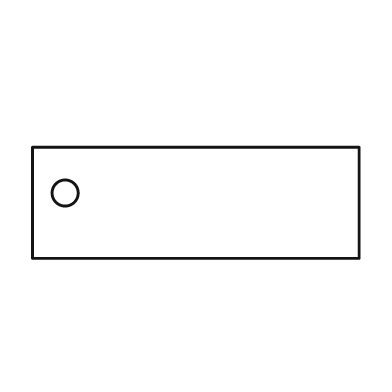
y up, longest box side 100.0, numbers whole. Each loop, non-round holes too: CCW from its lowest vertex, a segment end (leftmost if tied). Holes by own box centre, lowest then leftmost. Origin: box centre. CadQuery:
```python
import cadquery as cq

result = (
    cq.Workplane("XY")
    .moveTo(-50.0, -17.0)
    .lineTo(50.0, -17.0)
    .lineTo(50.0, 17.0)
    .lineTo(-50.0, 17.0)
    .close()
    .moveTo(-40.0, 3.0)
    .circle(4.0)
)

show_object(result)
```